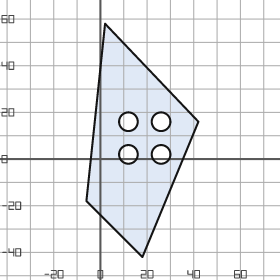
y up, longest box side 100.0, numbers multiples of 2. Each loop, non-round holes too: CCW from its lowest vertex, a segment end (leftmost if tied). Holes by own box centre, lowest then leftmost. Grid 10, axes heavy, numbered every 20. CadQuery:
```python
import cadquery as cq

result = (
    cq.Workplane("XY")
    .moveTo(18.0, -42.0)
    .lineTo(42.0, 16.0)
    .lineTo(2.0, 58.0)
    .lineTo(-6.0, -18.0)
    .close()
    .moveTo(12.0, 2.0)
    .circle(4.0)
    .moveTo(26.0, 2.0)
    .circle(4.0)
    .moveTo(12.0, 16.0)
    .circle(4.0)
    .moveTo(26.0, 16.0)
    .circle(4.0)
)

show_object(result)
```